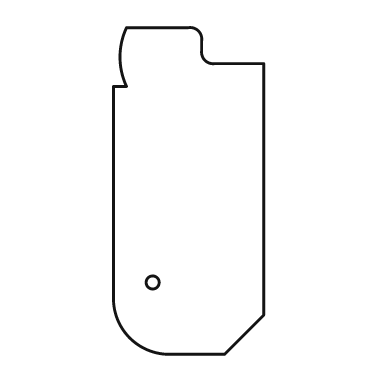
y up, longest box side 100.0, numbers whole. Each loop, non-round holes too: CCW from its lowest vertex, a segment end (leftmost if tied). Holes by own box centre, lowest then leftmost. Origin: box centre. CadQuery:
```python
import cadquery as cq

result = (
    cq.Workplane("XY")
    .moveTo(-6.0, -50.0)
    .lineTo(11.0, -50.0)
    .lineTo(23.0, -38.0)
    .lineTo(23.0, 39.0)
    .lineTo(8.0, 39.0)
    .threePointArc((5.0, 40.0), (4.0, 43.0))
    .lineTo(4.0, 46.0)
    .threePointArc((3.0, 49.0), (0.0, 50.0))
    .lineTo(-19.0, 50.0)
    .threePointArc((-21.0, 41.0), (-19.0, 32.0))
    .lineTo(-23.0, 32.0)
    .lineTo(-23.0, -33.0)
    .threePointArc((-18.0, -45.0), (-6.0, -50.0))
    .close()
    .moveTo(-11.0, -28.0)
    .circle(2.0)
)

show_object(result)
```